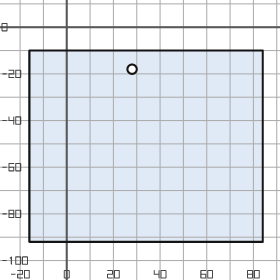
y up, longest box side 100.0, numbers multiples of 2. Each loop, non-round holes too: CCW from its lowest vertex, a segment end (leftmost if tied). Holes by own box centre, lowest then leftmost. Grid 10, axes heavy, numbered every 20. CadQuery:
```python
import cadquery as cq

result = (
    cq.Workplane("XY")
    .moveTo(-16.0, -92.0)
    .lineTo(84.0, -92.0)
    .lineTo(84.0, -10.0)
    .lineTo(-16.0, -10.0)
    .close()
    .moveTo(28.0, -18.0)
    .circle(2.0)
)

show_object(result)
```